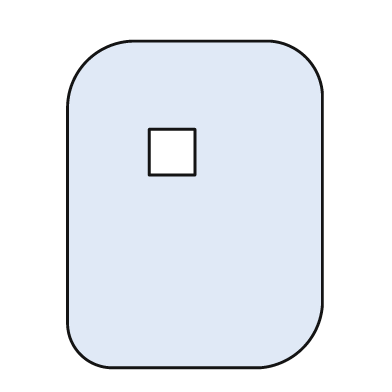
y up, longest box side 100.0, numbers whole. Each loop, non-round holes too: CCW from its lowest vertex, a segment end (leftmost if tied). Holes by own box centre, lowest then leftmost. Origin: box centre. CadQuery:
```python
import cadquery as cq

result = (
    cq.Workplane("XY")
    .moveTo(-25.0, -50.0)
    .lineTo(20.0, -50.0)
    .threePointArc((33.0, -44.0), (39.0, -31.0))
    .lineTo(39.0, 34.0)
    .threePointArc((34.0, 45.0), (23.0, 50.0))
    .lineTo(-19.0, 50.0)
    .threePointArc((-33.0, 44.0), (-39.0, 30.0))
    .lineTo(-39.0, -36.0)
    .threePointArc((-35.0, -46.0), (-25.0, -50.0))
    .close()
    .moveTo(-14.0, 9.0)
    .lineTo(0.0, 9.0)
    .lineTo(0.0, 23.0)
    .lineTo(-14.0, 23.0)
    .close()
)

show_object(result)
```